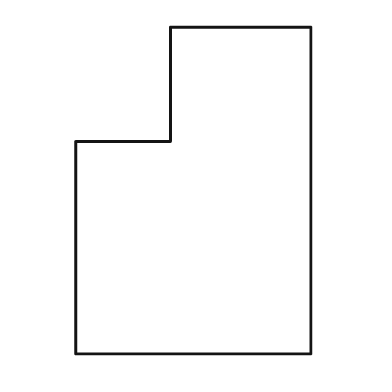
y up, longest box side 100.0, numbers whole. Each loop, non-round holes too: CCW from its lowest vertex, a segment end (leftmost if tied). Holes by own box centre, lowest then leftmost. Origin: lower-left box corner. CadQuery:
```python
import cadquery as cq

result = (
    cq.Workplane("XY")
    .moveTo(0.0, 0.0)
    .lineTo(72.0, 0.0)
    .lineTo(72.0, 100.0)
    .lineTo(29.0, 100.0)
    .lineTo(29.0, 65.0)
    .lineTo(0.0, 65.0)
    .close()
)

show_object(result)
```